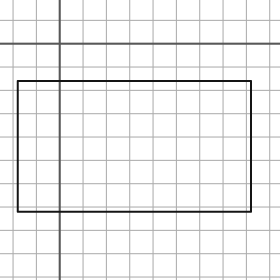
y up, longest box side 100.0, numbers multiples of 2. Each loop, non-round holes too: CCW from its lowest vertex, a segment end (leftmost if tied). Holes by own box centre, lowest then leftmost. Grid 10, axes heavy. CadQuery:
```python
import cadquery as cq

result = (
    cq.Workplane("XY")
    .moveTo(-18.0, -72.0)
    .lineTo(82.0, -72.0)
    .lineTo(82.0, -16.0)
    .lineTo(-18.0, -16.0)
    .close()
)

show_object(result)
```